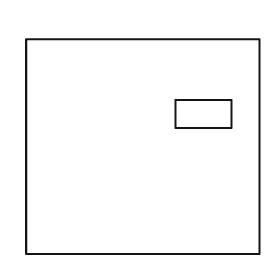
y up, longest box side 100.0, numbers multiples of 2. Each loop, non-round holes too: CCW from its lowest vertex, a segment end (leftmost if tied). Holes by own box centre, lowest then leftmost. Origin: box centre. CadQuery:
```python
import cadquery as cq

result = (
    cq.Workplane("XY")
    .moveTo(-50.0, -46.0)
    .lineTo(50.0, -46.0)
    .lineTo(50.0, 46.0)
    .lineTo(-50.0, 46.0)
    .close()
    .moveTo(14.0, 8.0)
    .lineTo(38.0, 8.0)
    .lineTo(38.0, 20.0)
    .lineTo(14.0, 20.0)
    .close()
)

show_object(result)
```